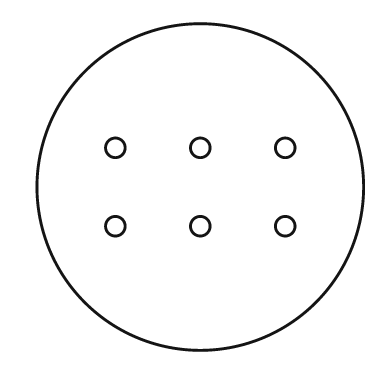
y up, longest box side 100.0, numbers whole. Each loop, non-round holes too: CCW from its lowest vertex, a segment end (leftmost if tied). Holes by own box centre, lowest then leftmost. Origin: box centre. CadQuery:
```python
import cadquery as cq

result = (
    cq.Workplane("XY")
    .moveTo(0.0, 0.0)
    .circle(50.0)
    .moveTo(-26.0, -12.0)
    .circle(3.0)
    .moveTo(0.0, -12.0)
    .circle(3.0)
    .moveTo(26.0, -12.0)
    .circle(3.0)
    .moveTo(-26.0, 12.0)
    .circle(3.0)
    .moveTo(0.0, 12.0)
    .circle(3.0)
    .moveTo(26.0, 12.0)
    .circle(3.0)
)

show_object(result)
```